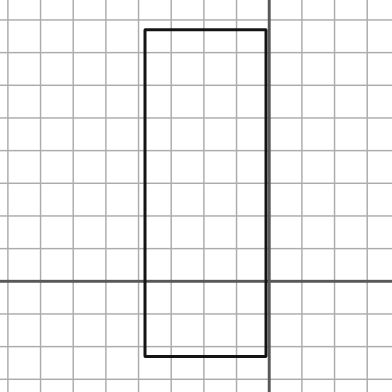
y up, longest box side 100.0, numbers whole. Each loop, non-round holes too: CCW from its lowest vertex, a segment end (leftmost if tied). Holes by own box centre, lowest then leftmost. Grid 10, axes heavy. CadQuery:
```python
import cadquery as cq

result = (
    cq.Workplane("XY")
    .moveTo(-38.0, -23.0)
    .lineTo(-1.0, -23.0)
    .lineTo(-1.0, 77.0)
    .lineTo(-38.0, 77.0)
    .close()
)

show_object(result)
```